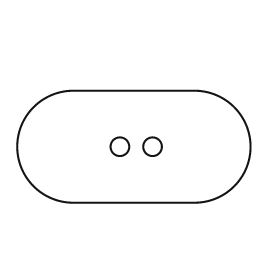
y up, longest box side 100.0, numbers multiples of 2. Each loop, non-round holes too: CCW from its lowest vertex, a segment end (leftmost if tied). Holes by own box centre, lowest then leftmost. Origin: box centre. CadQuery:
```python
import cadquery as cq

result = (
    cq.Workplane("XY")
    .moveTo(-26.0, -24.0)
    .lineTo(26.0, -24.0)
    .threePointArc((50.0, 0.0), (26.0, 24.0))
    .lineTo(-26.0, 24.0)
    .threePointArc((-50.0, 0.0), (-26.0, -24.0))
    .close()
    .moveTo(-6.0, 0.0)
    .circle(4.0)
    .moveTo(8.0, 0.0)
    .circle(4.0)
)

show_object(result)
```